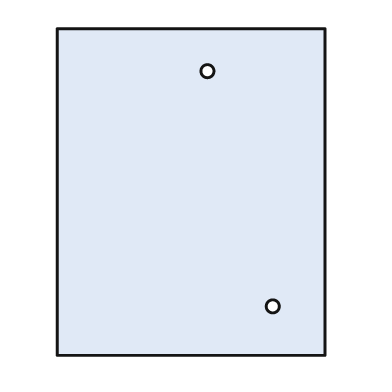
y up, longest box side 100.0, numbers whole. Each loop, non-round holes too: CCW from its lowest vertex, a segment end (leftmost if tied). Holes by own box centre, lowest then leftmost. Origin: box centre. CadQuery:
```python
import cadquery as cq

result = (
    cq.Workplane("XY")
    .moveTo(-41.0, -50.0)
    .lineTo(41.0, -50.0)
    .lineTo(41.0, 50.0)
    .lineTo(-41.0, 50.0)
    .close()
    .moveTo(25.0, -35.0)
    .circle(2.0)
    .moveTo(5.0, 37.0)
    .circle(2.0)
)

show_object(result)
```